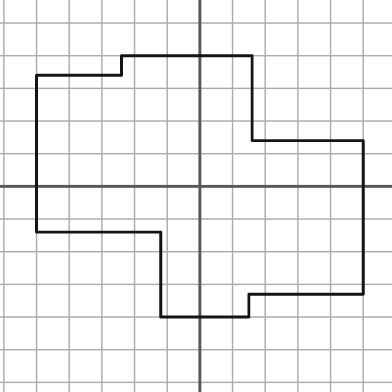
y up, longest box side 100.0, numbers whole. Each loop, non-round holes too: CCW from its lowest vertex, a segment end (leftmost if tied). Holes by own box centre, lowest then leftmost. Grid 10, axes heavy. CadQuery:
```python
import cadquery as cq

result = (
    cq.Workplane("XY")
    .moveTo(-12.0, -40.0)
    .lineTo(15.0, -40.0)
    .lineTo(15.0, -33.0)
    .lineTo(50.0, -33.0)
    .lineTo(50.0, 14.0)
    .lineTo(16.0, 14.0)
    .lineTo(16.0, 40.0)
    .lineTo(-24.0, 40.0)
    .lineTo(-24.0, 34.0)
    .lineTo(-50.0, 34.0)
    .lineTo(-50.0, -14.0)
    .lineTo(-12.0, -14.0)
    .close()
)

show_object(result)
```